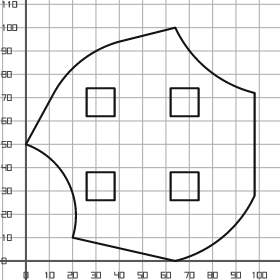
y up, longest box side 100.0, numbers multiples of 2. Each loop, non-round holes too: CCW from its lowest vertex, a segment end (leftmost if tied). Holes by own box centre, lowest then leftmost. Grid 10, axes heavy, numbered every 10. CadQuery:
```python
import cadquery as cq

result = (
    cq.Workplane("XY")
    .moveTo(64.0, 0.0)
    .threePointArc((84.0, 10.0), (98.0, 28.0))
    .lineTo(98.0, 72.0)
    .threePointArc((78.0, 82.0), (64.0, 100.0))
    .lineTo(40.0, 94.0)
    .threePointArc((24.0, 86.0), (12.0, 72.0))
    .lineTo(0.0, 50.0)
    .threePointArc((18.0, 34.0), (20.0, 10.0))
    .close()
    .moveTo(26.0, 26.0)
    .lineTo(38.0, 26.0)
    .lineTo(38.0, 38.0)
    .lineTo(26.0, 38.0)
    .close()
    .moveTo(62.0, 26.0)
    .lineTo(74.0, 26.0)
    .lineTo(74.0, 38.0)
    .lineTo(62.0, 38.0)
    .close()
    .moveTo(26.0, 62.0)
    .lineTo(38.0, 62.0)
    .lineTo(38.0, 74.0)
    .lineTo(26.0, 74.0)
    .close()
    .moveTo(62.0, 62.0)
    .lineTo(74.0, 62.0)
    .lineTo(74.0, 74.0)
    .lineTo(62.0, 74.0)
    .close()
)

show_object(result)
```